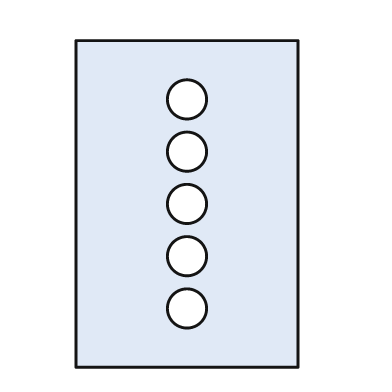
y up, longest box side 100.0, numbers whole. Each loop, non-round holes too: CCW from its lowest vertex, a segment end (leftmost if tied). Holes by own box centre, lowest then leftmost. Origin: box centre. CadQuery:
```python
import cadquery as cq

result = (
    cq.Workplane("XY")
    .moveTo(-34.0, -50.0)
    .lineTo(34.0, -50.0)
    .lineTo(34.0, 50.0)
    .lineTo(-34.0, 50.0)
    .close()
    .moveTo(0.0, -32.0)
    .circle(6.0)
    .moveTo(0.0, -16.0)
    .circle(6.0)
    .moveTo(0.0, 0.0)
    .circle(6.0)
    .moveTo(0.0, 16.0)
    .circle(6.0)
    .moveTo(0.0, 32.0)
    .circle(6.0)
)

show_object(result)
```